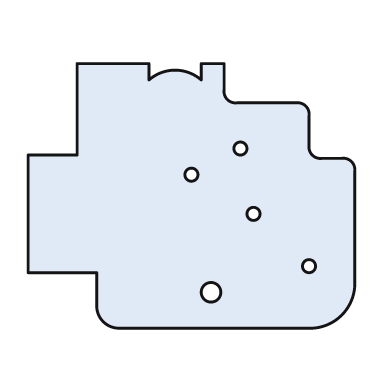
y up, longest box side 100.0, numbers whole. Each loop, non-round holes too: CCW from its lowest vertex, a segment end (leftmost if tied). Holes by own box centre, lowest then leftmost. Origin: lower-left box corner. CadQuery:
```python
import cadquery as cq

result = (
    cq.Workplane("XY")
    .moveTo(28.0, 0.0)
    .lineTo(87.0, 0.0)
    .threePointArc((96.0, 4.0), (100.0, 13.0))
    .lineTo(100.0, 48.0)
    .threePointArc((99.0, 51.0), (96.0, 52.0))
    .lineTo(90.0, 52.0)
    .threePointArc((87.0, 53.0), (86.0, 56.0))
    .lineTo(86.0, 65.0)
    .threePointArc((85.0, 68.0), (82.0, 69.0))
    .lineTo(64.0, 69.0)
    .threePointArc((61.0, 70.0), (60.0, 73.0))
    .lineTo(60.0, 81.0)
    .lineTo(53.0, 81.0)
    .lineTo(53.0, 76.0)
    .threePointArc((45.0, 79.0), (37.0, 76.0))
    .lineTo(37.0, 81.0)
    .lineTo(15.0, 81.0)
    .lineTo(15.0, 53.0)
    .lineTo(0.0, 53.0)
    .lineTo(0.0, 17.0)
    .lineTo(21.0, 17.0)
    .lineTo(21.0, 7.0)
    .threePointArc((23.0, 2.0), (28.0, 0.0))
    .close()
    .moveTo(56.0, 11.0)
    .circle(3.0)
    .moveTo(86.0, 19.0)
    .circle(2.0)
    .moveTo(69.0, 35.0)
    .circle(2.0)
    .moveTo(50.0, 47.0)
    .circle(2.0)
    .moveTo(65.0, 55.0)
    .circle(2.0)
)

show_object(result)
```